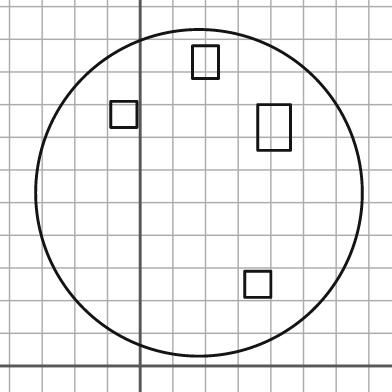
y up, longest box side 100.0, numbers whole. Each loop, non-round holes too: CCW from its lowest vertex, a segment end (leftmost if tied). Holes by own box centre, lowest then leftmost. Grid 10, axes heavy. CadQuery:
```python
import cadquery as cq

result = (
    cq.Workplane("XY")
    .moveTo(18.0, 53.0)
    .circle(50.0)
    .moveTo(32.0, 21.0)
    .lineTo(40.0, 21.0)
    .lineTo(40.0, 29.0)
    .lineTo(32.0, 29.0)
    .close()
    .moveTo(36.0, 66.0)
    .lineTo(46.0, 66.0)
    .lineTo(46.0, 80.0)
    .lineTo(36.0, 80.0)
    .close()
    .moveTo(-9.0, 73.0)
    .lineTo(-1.0, 73.0)
    .lineTo(-1.0, 81.0)
    .lineTo(-9.0, 81.0)
    .close()
    .moveTo(16.0, 88.0)
    .lineTo(24.0, 88.0)
    .lineTo(24.0, 98.0)
    .lineTo(16.0, 98.0)
    .close()
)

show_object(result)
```